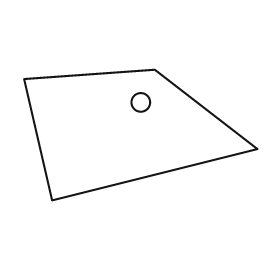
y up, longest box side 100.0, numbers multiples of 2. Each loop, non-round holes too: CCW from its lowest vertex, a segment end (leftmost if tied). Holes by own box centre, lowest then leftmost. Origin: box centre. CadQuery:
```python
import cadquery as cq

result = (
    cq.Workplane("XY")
    .moveTo(-38.0, -28.0)
    .lineTo(50.0, -6.0)
    .lineTo(6.0, 28.0)
    .lineTo(-50.0, 24.0)
    .close()
    .moveTo(0.0, 14.0)
    .circle(4.0)
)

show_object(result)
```